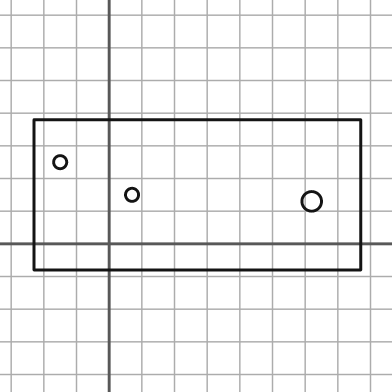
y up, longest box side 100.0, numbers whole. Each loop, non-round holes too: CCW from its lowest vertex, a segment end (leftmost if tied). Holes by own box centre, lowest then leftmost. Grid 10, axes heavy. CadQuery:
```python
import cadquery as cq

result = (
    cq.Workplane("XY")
    .moveTo(-23.0, -8.0)
    .lineTo(77.0, -8.0)
    .lineTo(77.0, 38.0)
    .lineTo(-23.0, 38.0)
    .close()
    .moveTo(62.0, 13.0)
    .circle(3.0)
    .moveTo(7.0, 15.0)
    .circle(2.0)
    .moveTo(-15.0, 25.0)
    .circle(2.0)
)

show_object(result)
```